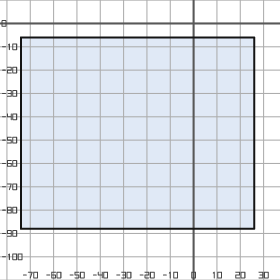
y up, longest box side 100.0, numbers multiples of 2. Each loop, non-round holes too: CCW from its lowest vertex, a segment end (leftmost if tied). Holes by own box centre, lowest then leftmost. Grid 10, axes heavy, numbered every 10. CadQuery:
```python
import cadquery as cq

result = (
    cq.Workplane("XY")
    .moveTo(-74.0, -88.0)
    .lineTo(26.0, -88.0)
    .lineTo(26.0, -6.0)
    .lineTo(-74.0, -6.0)
    .close()
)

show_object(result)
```